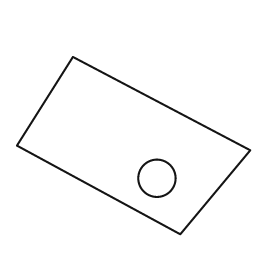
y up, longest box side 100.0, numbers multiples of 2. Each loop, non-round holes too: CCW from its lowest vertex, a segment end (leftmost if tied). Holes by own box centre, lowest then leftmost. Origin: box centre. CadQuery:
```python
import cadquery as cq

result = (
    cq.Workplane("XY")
    .moveTo(20.0, -38.0)
    .lineTo(50.0, -2.0)
    .lineTo(-26.0, 38.0)
    .lineTo(-50.0, 0.0)
    .close()
    .moveTo(10.0, -14.0)
    .circle(8.0)
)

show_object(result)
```